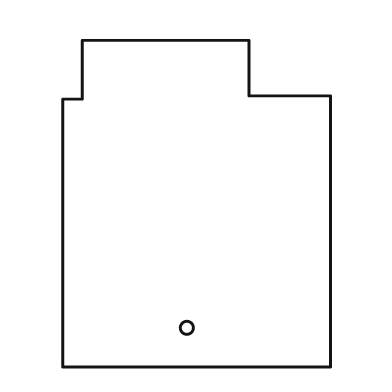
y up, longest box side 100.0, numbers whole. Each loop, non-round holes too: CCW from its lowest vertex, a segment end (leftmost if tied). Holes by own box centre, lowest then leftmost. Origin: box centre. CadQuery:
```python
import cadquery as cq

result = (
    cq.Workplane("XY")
    .moveTo(-41.0, -50.0)
    .lineTo(41.0, -50.0)
    .lineTo(41.0, 33.0)
    .lineTo(16.0, 33.0)
    .lineTo(16.0, 50.0)
    .lineTo(-35.0, 50.0)
    .lineTo(-35.0, 32.0)
    .lineTo(-41.0, 32.0)
    .close()
    .moveTo(-3.0, -38.0)
    .circle(2.0)
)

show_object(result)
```